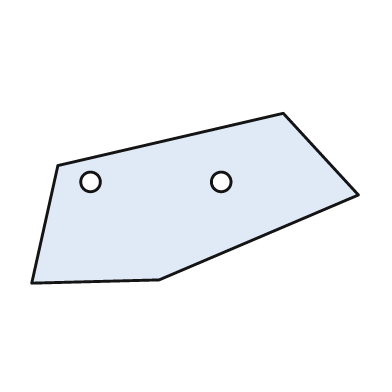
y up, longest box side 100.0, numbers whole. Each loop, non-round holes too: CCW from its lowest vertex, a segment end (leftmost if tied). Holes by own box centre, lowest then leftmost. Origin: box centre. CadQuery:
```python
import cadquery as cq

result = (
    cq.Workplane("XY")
    .moveTo(-50.0, -26.0)
    .lineTo(-11.0, -25.0)
    .lineTo(50.0, 1.0)
    .lineTo(27.0, 26.0)
    .lineTo(-42.0, 10.0)
    .close()
    .moveTo(-32.0, 5.0)
    .circle(3.0)
    .moveTo(8.0, 5.0)
    .circle(3.0)
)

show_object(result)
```